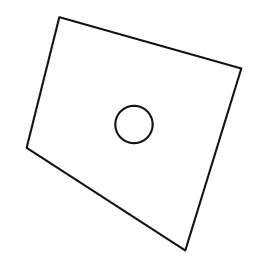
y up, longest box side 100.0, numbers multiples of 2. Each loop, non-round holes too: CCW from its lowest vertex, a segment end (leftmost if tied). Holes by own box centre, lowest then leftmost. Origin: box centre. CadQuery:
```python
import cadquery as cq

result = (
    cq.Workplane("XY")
    .moveTo(22.0, -50.0)
    .lineTo(46.0, 28.0)
    .lineTo(-32.0, 50.0)
    .lineTo(-46.0, -6.0)
    .close()
    .moveTo(0.0, 4.0)
    .circle(8.0)
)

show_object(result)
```